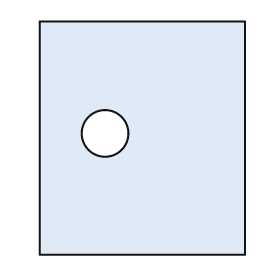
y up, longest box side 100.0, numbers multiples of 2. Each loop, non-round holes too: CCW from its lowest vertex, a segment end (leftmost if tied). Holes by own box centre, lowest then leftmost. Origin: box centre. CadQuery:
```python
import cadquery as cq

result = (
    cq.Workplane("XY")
    .moveTo(-44.0, -50.0)
    .lineTo(44.0, -50.0)
    .lineTo(44.0, 50.0)
    .lineTo(-44.0, 50.0)
    .close()
    .moveTo(-16.0, 2.0)
    .circle(10.0)
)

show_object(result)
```